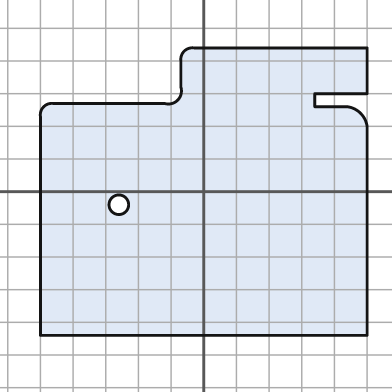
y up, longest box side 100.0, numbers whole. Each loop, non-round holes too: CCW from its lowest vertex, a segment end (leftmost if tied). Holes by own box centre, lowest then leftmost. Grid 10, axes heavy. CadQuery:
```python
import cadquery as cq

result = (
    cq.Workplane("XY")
    .moveTo(-50.0, -44.0)
    .lineTo(50.0, -44.0)
    .lineTo(50.0, 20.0)
    .threePointArc((48.0, 24.0), (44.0, 26.0))
    .lineTo(34.0, 26.0)
    .lineTo(34.0, 30.0)
    .lineTo(50.0, 30.0)
    .lineTo(50.0, 44.0)
    .lineTo(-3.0, 44.0)
    .threePointArc((-6.0, 43.0), (-7.0, 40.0))
    .lineTo(-7.0, 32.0)
    .threePointArc((-8.0, 28.0), (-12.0, 27.0))
    .lineTo(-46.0, 27.0)
    .threePointArc((-49.0, 26.0), (-50.0, 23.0))
    .close()
    .moveTo(-26.0, -4.0)
    .circle(3.0)
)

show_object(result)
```